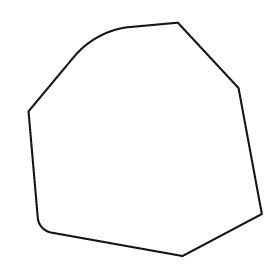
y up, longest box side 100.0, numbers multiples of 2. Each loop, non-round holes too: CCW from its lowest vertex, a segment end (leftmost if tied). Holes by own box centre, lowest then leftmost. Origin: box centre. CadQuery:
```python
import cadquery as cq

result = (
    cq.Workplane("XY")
    .moveTo(16.0, -50.0)
    .lineTo(50.0, -32.0)
    .lineTo(40.0, 22.0)
    .lineTo(14.0, 50.0)
    .lineTo(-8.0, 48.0)
    .threePointArc((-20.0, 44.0), (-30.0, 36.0))
    .lineTo(-50.0, 12.0)
    .lineTo(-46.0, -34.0)
    .threePointArc((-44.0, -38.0), (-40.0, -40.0))
    .close()
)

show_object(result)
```